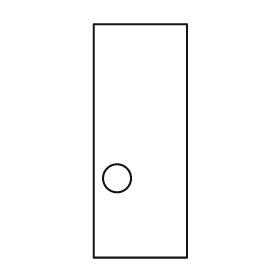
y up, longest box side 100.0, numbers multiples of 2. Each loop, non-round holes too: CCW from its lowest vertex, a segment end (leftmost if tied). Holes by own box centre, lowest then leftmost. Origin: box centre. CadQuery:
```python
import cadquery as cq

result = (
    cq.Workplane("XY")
    .moveTo(-20.0, -50.0)
    .lineTo(20.0, -50.0)
    .lineTo(20.0, 50.0)
    .lineTo(-20.0, 50.0)
    .close()
    .moveTo(-10.0, -16.0)
    .circle(6.0)
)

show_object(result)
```